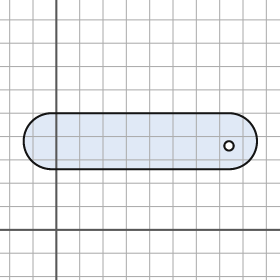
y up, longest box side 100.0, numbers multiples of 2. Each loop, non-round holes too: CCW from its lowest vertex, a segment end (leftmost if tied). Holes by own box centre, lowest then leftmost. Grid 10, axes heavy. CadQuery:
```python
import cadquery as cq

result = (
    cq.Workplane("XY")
    .moveTo(-2.0, 26.0)
    .lineTo(74.0, 26.0)
    .threePointArc((86.0, 38.0), (74.0, 50.0))
    .lineTo(-2.0, 50.0)
    .threePointArc((-14.0, 38.0), (-2.0, 26.0))
    .close()
    .moveTo(74.0, 36.0)
    .circle(2.0)
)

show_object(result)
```